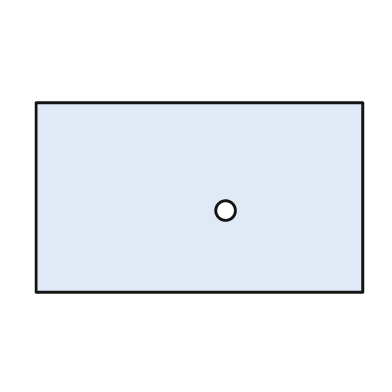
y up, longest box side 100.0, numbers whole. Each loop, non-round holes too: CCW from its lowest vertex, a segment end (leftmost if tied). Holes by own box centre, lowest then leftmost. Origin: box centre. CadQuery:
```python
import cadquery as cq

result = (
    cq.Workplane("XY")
    .moveTo(-50.0, -29.0)
    .lineTo(50.0, -29.0)
    .lineTo(50.0, 29.0)
    .lineTo(-50.0, 29.0)
    .close()
    .moveTo(8.0, -4.0)
    .circle(3.0)
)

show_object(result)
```